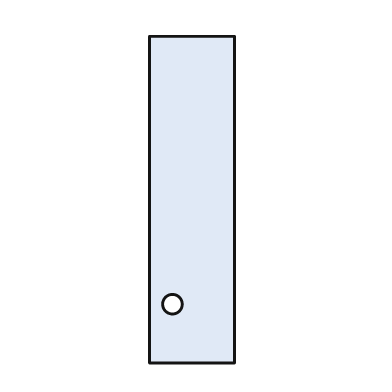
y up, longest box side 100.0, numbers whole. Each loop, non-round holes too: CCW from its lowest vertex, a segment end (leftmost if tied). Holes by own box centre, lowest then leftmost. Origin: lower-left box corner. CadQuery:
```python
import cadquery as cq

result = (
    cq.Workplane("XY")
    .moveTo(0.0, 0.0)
    .lineTo(26.0, 0.0)
    .lineTo(26.0, 100.0)
    .lineTo(0.0, 100.0)
    .close()
    .moveTo(7.0, 18.0)
    .circle(3.0)
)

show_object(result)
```